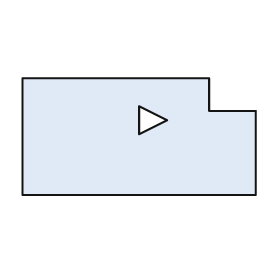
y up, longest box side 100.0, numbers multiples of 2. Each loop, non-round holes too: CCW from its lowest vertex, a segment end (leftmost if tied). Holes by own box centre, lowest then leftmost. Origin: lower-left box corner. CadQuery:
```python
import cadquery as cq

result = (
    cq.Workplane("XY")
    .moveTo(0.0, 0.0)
    .lineTo(100.0, 0.0)
    .lineTo(100.0, 36.0)
    .lineTo(80.0, 36.0)
    .lineTo(80.0, 50.0)
    .lineTo(0.0, 50.0)
    .close()
    .moveTo(50.0, 26.0)
    .lineTo(62.0, 32.0)
    .lineTo(50.0, 38.0)
    .close()
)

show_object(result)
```